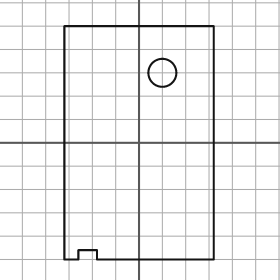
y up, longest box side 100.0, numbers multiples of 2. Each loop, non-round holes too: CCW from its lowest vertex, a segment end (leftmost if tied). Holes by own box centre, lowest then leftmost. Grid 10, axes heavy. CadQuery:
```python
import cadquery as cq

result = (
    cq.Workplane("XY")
    .moveTo(-32.0, -50.0)
    .lineTo(-26.0, -50.0)
    .lineTo(-26.0, -46.0)
    .lineTo(-18.0, -46.0)
    .lineTo(-18.0, -50.0)
    .lineTo(32.0, -50.0)
    .lineTo(32.0, 50.0)
    .lineTo(-32.0, 50.0)
    .close()
    .moveTo(10.0, 30.0)
    .circle(6.0)
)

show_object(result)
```